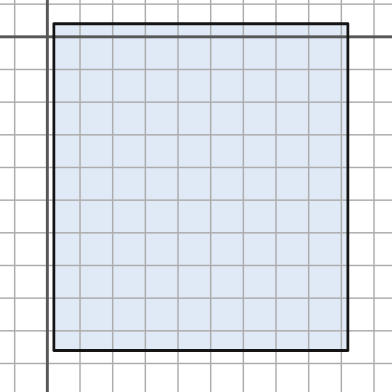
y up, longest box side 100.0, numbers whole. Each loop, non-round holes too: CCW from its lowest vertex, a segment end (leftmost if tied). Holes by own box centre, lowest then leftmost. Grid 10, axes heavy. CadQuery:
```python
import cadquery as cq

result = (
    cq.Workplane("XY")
    .moveTo(2.0, -96.0)
    .lineTo(92.0, -96.0)
    .lineTo(92.0, 4.0)
    .lineTo(2.0, 4.0)
    .close()
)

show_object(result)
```